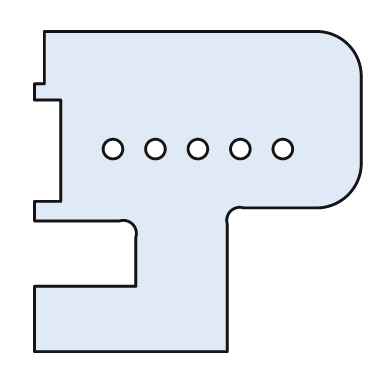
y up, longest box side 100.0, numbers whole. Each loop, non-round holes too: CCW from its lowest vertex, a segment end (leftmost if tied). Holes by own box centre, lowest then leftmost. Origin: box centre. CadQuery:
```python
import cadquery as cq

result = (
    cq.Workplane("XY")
    .moveTo(-50.0, -49.0)
    .lineTo(9.0, -49.0)
    .lineTo(9.0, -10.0)
    .threePointArc((10.0, -6.0), (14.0, -5.0))
    .lineTo(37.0, -5.0)
    .threePointArc((46.0, -1.0), (50.0, 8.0))
    .lineTo(50.0, 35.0)
    .threePointArc((46.0, 45.0), (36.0, 49.0))
    .lineTo(-47.0, 49.0)
    .lineTo(-47.0, 33.0)
    .lineTo(-50.0, 33.0)
    .lineTo(-50.0, 28.0)
    .lineTo(-42.0, 28.0)
    .lineTo(-42.0, -3.0)
    .lineTo(-50.0, -3.0)
    .lineTo(-50.0, -9.0)
    .lineTo(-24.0, -9.0)
    .threePointArc((-20.0, -10.0), (-19.0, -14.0))
    .lineTo(-19.0, -29.0)
    .lineTo(-50.0, -29.0)
    .close()
    .moveTo(-26.0, 13.0)
    .circle(3.0)
    .moveTo(-13.0, 13.0)
    .circle(3.0)
    .moveTo(0.0, 13.0)
    .circle(3.0)
    .moveTo(13.0, 13.0)
    .circle(3.0)
    .moveTo(26.0, 13.0)
    .circle(3.0)
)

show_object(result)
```